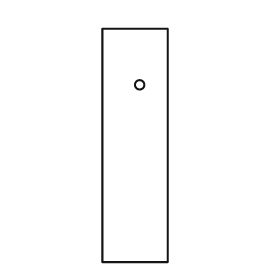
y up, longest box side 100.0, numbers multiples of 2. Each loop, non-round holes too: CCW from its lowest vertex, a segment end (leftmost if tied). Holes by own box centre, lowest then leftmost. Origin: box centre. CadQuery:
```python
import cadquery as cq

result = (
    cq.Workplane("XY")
    .moveTo(-14.0, -50.0)
    .lineTo(14.0, -50.0)
    .lineTo(14.0, 50.0)
    .lineTo(-14.0, 50.0)
    .close()
    .moveTo(2.0, 26.0)
    .circle(2.0)
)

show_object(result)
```